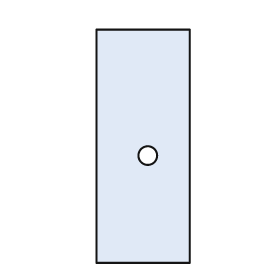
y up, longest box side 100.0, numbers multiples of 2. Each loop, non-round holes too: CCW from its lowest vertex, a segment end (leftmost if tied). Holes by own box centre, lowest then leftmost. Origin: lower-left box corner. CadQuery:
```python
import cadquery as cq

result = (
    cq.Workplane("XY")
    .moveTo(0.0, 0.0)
    .lineTo(40.0, 0.0)
    .lineTo(40.0, 100.0)
    .lineTo(0.0, 100.0)
    .close()
    .moveTo(22.0, 46.0)
    .circle(4.0)
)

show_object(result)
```